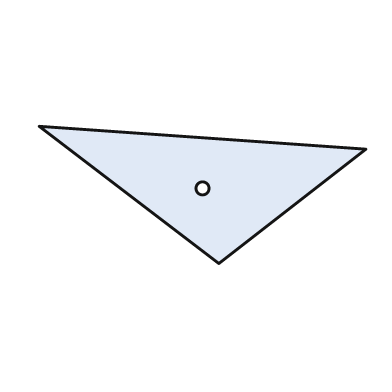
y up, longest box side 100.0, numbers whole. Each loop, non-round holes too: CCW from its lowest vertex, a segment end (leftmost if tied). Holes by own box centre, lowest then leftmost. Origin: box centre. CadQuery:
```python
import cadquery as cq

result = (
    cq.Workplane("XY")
    .moveTo(5.0, -21.0)
    .lineTo(50.0, 14.0)
    .lineTo(-50.0, 21.0)
    .close()
    .moveTo(0.0, 2.0)
    .circle(2.0)
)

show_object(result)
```